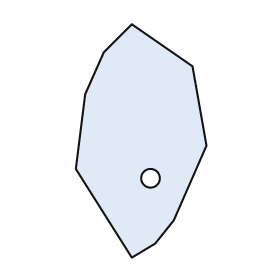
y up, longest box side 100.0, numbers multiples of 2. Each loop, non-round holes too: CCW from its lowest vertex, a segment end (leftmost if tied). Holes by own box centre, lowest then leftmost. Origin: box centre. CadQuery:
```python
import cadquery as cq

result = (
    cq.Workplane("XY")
    .moveTo(-4.0, -50.0)
    .lineTo(6.0, -44.0)
    .lineTo(14.0, -34.0)
    .lineTo(28.0, -2.0)
    .lineTo(22.0, 32.0)
    .lineTo(-4.0, 50.0)
    .lineTo(-16.0, 38.0)
    .lineTo(-24.0, 20.0)
    .lineTo(-28.0, -12.0)
    .close()
    .moveTo(4.0, -16.0)
    .circle(4.0)
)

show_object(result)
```